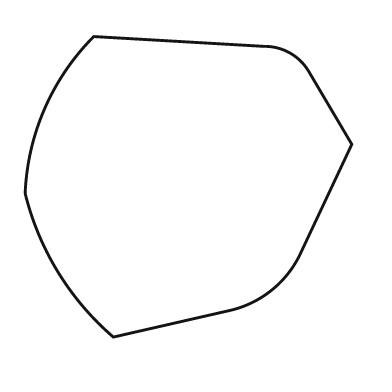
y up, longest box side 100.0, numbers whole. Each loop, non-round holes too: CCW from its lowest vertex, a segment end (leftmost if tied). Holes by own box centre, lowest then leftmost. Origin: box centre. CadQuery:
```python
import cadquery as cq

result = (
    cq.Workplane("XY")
    .moveTo(-23.0, -46.0)
    .lineTo(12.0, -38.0)
    .threePointArc((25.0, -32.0), (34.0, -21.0))
    .lineTo(50.0, 13.0)
    .lineTo(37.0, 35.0)
    .threePointArc((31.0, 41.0), (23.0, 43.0))
    .lineTo(-29.0, 46.0)
    .threePointArc((-44.0, 24.0), (-50.0, -2.0))
    .threePointArc((-40.0, -26.0), (-23.0, -46.0))
    .close()
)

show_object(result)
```